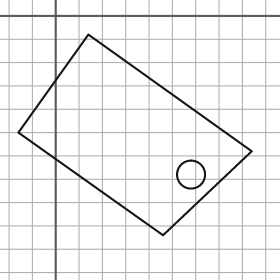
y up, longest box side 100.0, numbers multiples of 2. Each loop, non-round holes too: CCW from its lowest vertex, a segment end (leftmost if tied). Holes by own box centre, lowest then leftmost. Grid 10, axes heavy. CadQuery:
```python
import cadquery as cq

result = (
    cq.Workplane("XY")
    .moveTo(46.0, -94.0)
    .lineTo(84.0, -58.0)
    .lineTo(14.0, -8.0)
    .lineTo(-16.0, -50.0)
    .close()
    .moveTo(58.0, -68.0)
    .circle(6.0)
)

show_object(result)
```